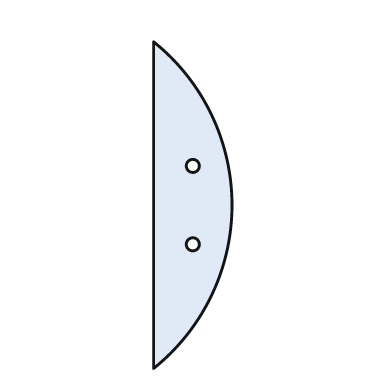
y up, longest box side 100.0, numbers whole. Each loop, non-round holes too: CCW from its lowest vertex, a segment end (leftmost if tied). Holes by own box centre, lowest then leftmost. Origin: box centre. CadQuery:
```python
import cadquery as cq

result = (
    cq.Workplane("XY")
    .moveTo(-12.0, -50.0)
    .threePointArc((12.0, 0.0), (-12.0, 50.0))
    .close()
    .moveTo(0.0, -12.0)
    .circle(2.0)
    .moveTo(0.0, 12.0)
    .circle(2.0)
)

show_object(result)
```